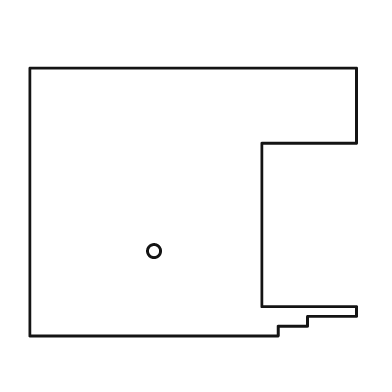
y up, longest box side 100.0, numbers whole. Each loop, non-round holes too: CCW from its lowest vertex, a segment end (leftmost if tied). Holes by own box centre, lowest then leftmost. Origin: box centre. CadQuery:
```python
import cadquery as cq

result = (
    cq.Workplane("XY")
    .moveTo(-50.0, -41.0)
    .lineTo(26.0, -41.0)
    .lineTo(26.0, -38.0)
    .lineTo(35.0, -38.0)
    .lineTo(35.0, -35.0)
    .lineTo(50.0, -35.0)
    .lineTo(50.0, -32.0)
    .lineTo(21.0, -32.0)
    .lineTo(21.0, 18.0)
    .lineTo(50.0, 18.0)
    .lineTo(50.0, 41.0)
    .lineTo(-50.0, 41.0)
    .close()
    .moveTo(-12.0, -15.0)
    .circle(2.0)
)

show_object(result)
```